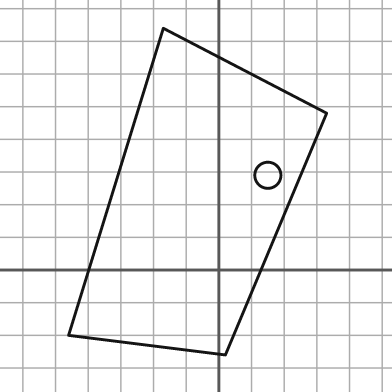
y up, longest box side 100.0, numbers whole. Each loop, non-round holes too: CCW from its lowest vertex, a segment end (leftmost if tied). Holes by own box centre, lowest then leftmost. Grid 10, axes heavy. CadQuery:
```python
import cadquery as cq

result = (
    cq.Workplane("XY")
    .moveTo(2.0, -26.0)
    .lineTo(33.0, 48.0)
    .lineTo(-17.0, 74.0)
    .lineTo(-46.0, -20.0)
    .close()
    .moveTo(15.0, 29.0)
    .circle(4.0)
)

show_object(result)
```